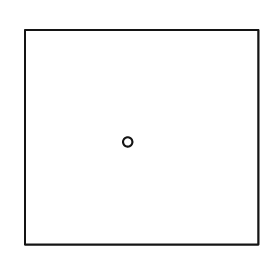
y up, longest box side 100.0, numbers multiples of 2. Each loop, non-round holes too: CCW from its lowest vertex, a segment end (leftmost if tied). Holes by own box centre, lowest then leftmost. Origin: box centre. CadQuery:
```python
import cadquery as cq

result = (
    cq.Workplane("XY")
    .moveTo(-50.0, -46.0)
    .lineTo(50.0, -46.0)
    .lineTo(50.0, 46.0)
    .lineTo(-50.0, 46.0)
    .close()
    .moveTo(-6.0, -2.0)
    .circle(2.0)
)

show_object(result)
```